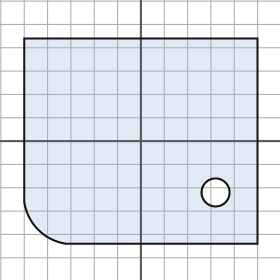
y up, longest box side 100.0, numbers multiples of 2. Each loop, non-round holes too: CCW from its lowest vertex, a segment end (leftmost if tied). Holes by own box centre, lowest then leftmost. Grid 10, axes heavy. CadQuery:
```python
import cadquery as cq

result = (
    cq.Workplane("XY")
    .moveTo(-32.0, -44.0)
    .lineTo(50.0, -44.0)
    .lineTo(50.0, 44.0)
    .lineTo(-50.0, 44.0)
    .lineTo(-50.0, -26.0)
    .threePointArc((-44.0, -38.0), (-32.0, -44.0))
    .close()
    .moveTo(32.0, -22.0)
    .circle(6.0)
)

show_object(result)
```